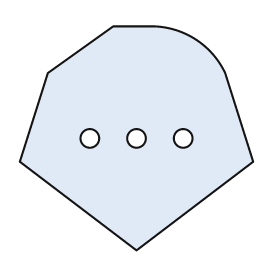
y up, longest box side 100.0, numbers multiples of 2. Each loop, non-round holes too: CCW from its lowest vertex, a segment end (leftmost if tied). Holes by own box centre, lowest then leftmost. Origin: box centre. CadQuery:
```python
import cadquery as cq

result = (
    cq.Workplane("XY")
    .moveTo(0.0, -48.0)
    .lineTo(50.0, -10.0)
    .lineTo(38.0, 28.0)
    .threePointArc((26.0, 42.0), (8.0, 48.0))
    .lineTo(-10.0, 48.0)
    .lineTo(-38.0, 28.0)
    .lineTo(-50.0, -10.0)
    .close()
    .moveTo(-20.0, 0.0)
    .circle(4.0)
    .moveTo(0.0, 0.0)
    .circle(4.0)
    .moveTo(20.0, 0.0)
    .circle(4.0)
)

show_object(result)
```